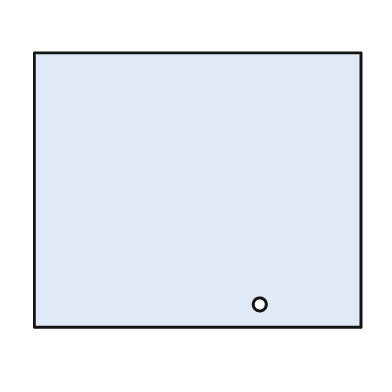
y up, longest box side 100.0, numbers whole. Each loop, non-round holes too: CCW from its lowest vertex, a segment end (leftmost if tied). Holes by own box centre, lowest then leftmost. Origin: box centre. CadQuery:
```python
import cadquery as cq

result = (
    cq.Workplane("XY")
    .moveTo(-50.0, -42.0)
    .lineTo(50.0, -42.0)
    .lineTo(50.0, 42.0)
    .lineTo(-50.0, 42.0)
    .close()
    .moveTo(19.0, -35.0)
    .circle(2.0)
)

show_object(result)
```